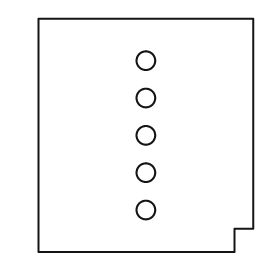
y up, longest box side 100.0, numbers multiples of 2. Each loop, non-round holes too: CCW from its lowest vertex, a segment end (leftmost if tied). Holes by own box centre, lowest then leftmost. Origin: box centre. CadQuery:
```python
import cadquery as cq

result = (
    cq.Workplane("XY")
    .moveTo(-46.0, -50.0)
    .lineTo(38.0, -50.0)
    .lineTo(38.0, -40.0)
    .lineTo(46.0, -40.0)
    .lineTo(46.0, 50.0)
    .lineTo(-46.0, 50.0)
    .close()
    .moveTo(0.0, -32.0)
    .circle(4.0)
    .moveTo(0.0, -16.0)
    .circle(4.0)
    .moveTo(0.0, 0.0)
    .circle(4.0)
    .moveTo(0.0, 16.0)
    .circle(4.0)
    .moveTo(0.0, 32.0)
    .circle(4.0)
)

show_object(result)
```